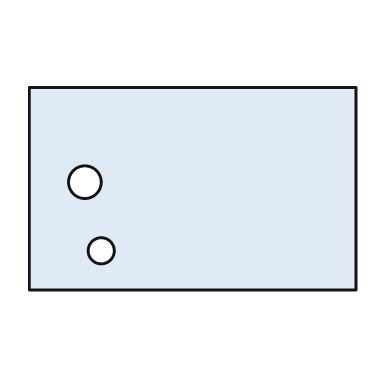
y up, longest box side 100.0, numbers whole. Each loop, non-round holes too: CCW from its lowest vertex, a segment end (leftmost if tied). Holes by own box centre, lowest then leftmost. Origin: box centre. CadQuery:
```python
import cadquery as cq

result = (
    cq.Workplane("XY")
    .moveTo(-50.0, -31.0)
    .lineTo(50.0, -31.0)
    .lineTo(50.0, 31.0)
    .lineTo(-50.0, 31.0)
    .close()
    .moveTo(-28.0, -19.0)
    .circle(4.0)
    .moveTo(-33.0, 2.0)
    .circle(5.0)
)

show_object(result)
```